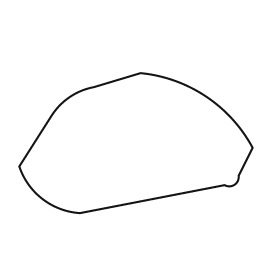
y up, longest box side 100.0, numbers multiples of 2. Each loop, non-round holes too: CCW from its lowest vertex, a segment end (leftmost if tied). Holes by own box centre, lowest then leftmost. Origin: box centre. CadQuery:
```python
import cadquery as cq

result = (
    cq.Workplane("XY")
    .moveTo(-24.0, -30.0)
    .lineTo(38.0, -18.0)
    .threePointArc((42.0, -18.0), (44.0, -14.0))
    .lineTo(50.0, -2.0)
    .threePointArc((30.0, 20.0), (2.0, 30.0))
    .lineTo(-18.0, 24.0)
    .threePointArc((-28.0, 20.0), (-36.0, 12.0))
    .lineTo(-50.0, -10.0)
    .threePointArc((-40.0, -24.0), (-24.0, -30.0))
    .close()
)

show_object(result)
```